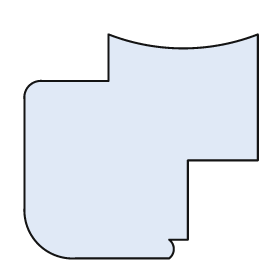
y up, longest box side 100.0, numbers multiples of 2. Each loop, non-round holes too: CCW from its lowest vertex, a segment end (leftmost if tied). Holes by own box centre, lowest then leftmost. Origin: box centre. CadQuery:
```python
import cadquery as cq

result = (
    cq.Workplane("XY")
    .moveTo(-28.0, -48.0)
    .lineTo(12.0, -48.0)
    .threePointArc((14.0, -44.0), (12.0, -40.0))
    .lineTo(20.0, -40.0)
    .lineTo(20.0, -6.0)
    .lineTo(50.0, -6.0)
    .lineTo(50.0, 48.0)
    .threePointArc((18.0, 42.0), (-14.0, 48.0))
    .lineTo(-14.0, 28.0)
    .lineTo(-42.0, 28.0)
    .threePointArc((-48.0, 26.0), (-50.0, 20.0))
    .lineTo(-50.0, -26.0)
    .threePointArc((-44.0, -42.0), (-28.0, -48.0))
    .close()
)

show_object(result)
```